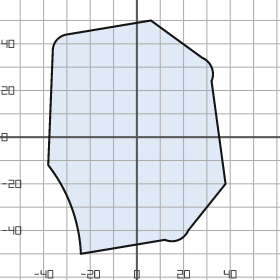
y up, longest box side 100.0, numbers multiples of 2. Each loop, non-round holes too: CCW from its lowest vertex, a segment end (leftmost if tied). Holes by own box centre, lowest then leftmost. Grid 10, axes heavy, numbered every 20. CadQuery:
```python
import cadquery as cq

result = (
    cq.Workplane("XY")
    .moveTo(-24.0, -50.0)
    .lineTo(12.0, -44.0)
    .threePointArc((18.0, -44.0), (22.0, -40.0))
    .lineTo(38.0, -20.0)
    .lineTo(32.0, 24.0)
    .threePointArc((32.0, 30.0), (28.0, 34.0))
    .lineTo(6.0, 50.0)
    .lineTo(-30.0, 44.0)
    .threePointArc((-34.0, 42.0), (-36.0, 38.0))
    .lineTo(-38.0, -12.0)
    .threePointArc((-28.0, -30.0), (-24.0, -50.0))
    .close()
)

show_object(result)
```